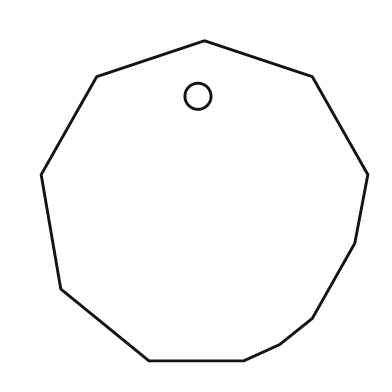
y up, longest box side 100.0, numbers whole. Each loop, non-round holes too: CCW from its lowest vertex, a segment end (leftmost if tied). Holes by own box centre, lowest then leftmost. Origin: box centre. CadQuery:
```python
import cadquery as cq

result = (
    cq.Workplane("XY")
    .moveTo(-17.0, -49.0)
    .lineTo(12.0, -49.0)
    .lineTo(23.0, -44.0)
    .lineTo(33.0, -36.0)
    .lineTo(46.0, -13.0)
    .lineTo(50.0, 8.0)
    .lineTo(33.0, 38.0)
    .lineTo(0.0, 49.0)
    .lineTo(-33.0, 38.0)
    .lineTo(-50.0, 8.0)
    .lineTo(-44.0, -27.0)
    .close()
    .moveTo(-2.0, 32.0)
    .circle(4.0)
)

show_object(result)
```